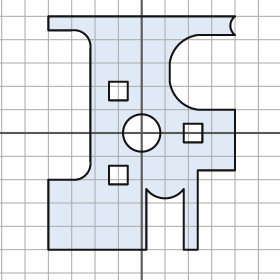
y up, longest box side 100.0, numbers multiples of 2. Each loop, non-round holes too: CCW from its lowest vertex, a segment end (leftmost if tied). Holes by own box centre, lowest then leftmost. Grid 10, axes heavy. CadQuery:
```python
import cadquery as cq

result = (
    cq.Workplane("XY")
    .moveTo(-40.0, -50.0)
    .lineTo(2.0, -50.0)
    .lineTo(2.0, -24.0)
    .threePointArc((10.0, -28.0), (18.0, -24.0))
    .lineTo(18.0, -50.0)
    .lineTo(24.0, -50.0)
    .lineTo(24.0, -16.0)
    .lineTo(40.0, -16.0)
    .lineTo(40.0, 10.0)
    .lineTo(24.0, 10.0)
    .threePointArc((16.0, 14.0), (12.0, 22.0))
    .lineTo(12.0, 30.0)
    .threePointArc((16.0, 38.0), (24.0, 42.0))
    .lineTo(40.0, 42.0)
    .threePointArc((38.0, 46.0), (40.0, 50.0))
    .lineTo(-40.0, 50.0)
    .lineTo(-40.0, 44.0)
    .lineTo(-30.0, 44.0)
    .threePointArc((-24.0, 42.0), (-22.0, 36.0))
    .lineTo(-22.0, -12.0)
    .threePointArc((-24.0, -18.0), (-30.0, -20.0))
    .lineTo(-40.0, -20.0)
    .close()
    .moveTo(-14.0, -22.0)
    .lineTo(-6.0, -22.0)
    .lineTo(-6.0, -14.0)
    .lineTo(-14.0, -14.0)
    .close()
    .moveTo(0.0, 0.0)
    .circle(8.0)
    .moveTo(18.0, -4.0)
    .lineTo(26.0, -4.0)
    .lineTo(26.0, 4.0)
    .lineTo(18.0, 4.0)
    .close()
    .moveTo(-14.0, 14.0)
    .lineTo(-6.0, 14.0)
    .lineTo(-6.0, 22.0)
    .lineTo(-14.0, 22.0)
    .close()
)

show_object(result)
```